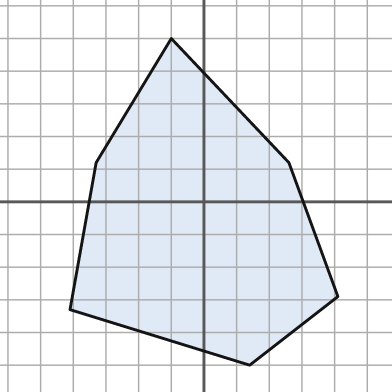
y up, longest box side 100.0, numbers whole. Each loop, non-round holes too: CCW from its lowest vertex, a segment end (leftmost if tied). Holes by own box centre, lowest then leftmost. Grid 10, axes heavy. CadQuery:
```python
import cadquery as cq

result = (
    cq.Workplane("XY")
    .moveTo(14.0, -50.0)
    .lineTo(41.0, -29.0)
    .lineTo(26.0, 12.0)
    .lineTo(-10.0, 50.0)
    .lineTo(-33.0, 12.0)
    .lineTo(-41.0, -33.0)
    .close()
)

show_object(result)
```